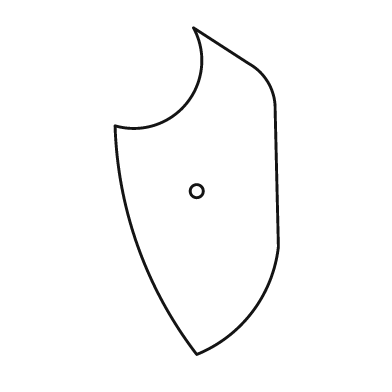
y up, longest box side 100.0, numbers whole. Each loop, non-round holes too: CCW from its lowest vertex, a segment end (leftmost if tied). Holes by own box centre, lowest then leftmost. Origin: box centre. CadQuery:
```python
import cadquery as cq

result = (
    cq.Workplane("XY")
    .moveTo(0.0, -50.0)
    .threePointArc((17.0, -37.0), (25.0, -17.0))
    .lineTo(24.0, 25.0)
    .threePointArc((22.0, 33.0), (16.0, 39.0))
    .lineTo(-1.0, 50.0)
    .threePointArc((-3.0, 27.0), (-25.0, 20.0))
    .threePointArc((-18.0, -17.0), (0.0, -50.0))
    .close()
    .moveTo(0.0, 0.0)
    .circle(2.0)
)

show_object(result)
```